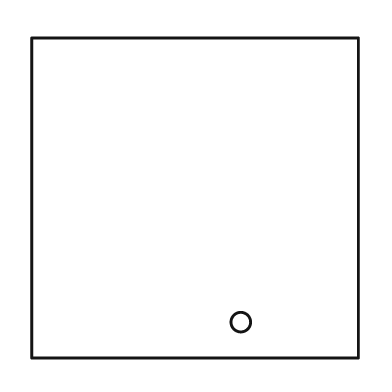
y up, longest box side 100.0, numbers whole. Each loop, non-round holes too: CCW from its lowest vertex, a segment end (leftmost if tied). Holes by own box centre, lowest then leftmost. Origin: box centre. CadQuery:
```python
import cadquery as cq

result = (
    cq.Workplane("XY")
    .moveTo(-50.0, -49.0)
    .lineTo(50.0, -49.0)
    .lineTo(50.0, 49.0)
    .lineTo(-50.0, 49.0)
    .close()
    .moveTo(14.0, -38.0)
    .circle(3.0)
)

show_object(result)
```